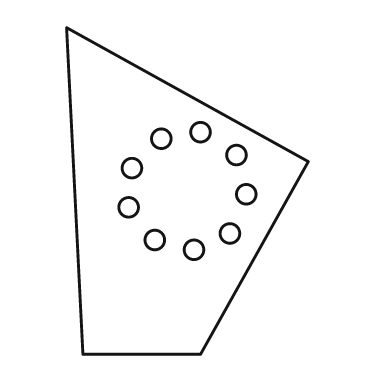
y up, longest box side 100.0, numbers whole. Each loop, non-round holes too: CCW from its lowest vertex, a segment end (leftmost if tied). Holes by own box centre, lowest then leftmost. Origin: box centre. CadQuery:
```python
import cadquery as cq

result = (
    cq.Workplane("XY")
    .moveTo(-32.0, -50.0)
    .lineTo(4.0, -50.0)
    .lineTo(37.0, 9.0)
    .lineTo(-37.0, 50.0)
    .close()
    .moveTo(2.0, -18.0)
    .circle(3.0)
    .moveTo(-10.0, -15.0)
    .circle(3.0)
    .moveTo(13.0, -13.0)
    .circle(3.0)
    .moveTo(-18.0, -5.0)
    .circle(3.0)
    .moveTo(18.0, -1.0)
    .circle(3.0)
    .moveTo(-17.0, 7.0)
    .circle(3.0)
    .moveTo(15.0, 11.0)
    .circle(3.0)
    .moveTo(-8.0, 16.0)
    .circle(3.0)
    .moveTo(4.0, 18.0)
    .circle(3.0)
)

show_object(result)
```